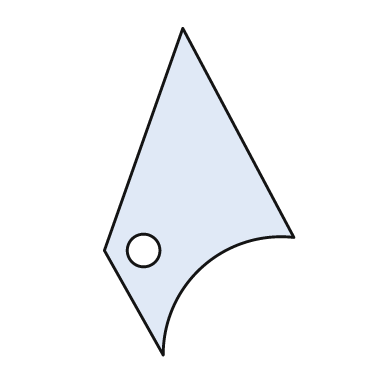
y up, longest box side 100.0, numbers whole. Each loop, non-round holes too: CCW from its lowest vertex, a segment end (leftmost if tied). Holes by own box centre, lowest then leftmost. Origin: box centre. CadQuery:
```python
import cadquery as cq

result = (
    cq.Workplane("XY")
    .moveTo(-11.0, -50.0)
    .threePointArc((1.0, -23.0), (29.0, -14.0))
    .lineTo(-5.0, 50.0)
    .lineTo(-29.0, -18.0)
    .close()
    .moveTo(-17.0, -18.0)
    .circle(5.0)
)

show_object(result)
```